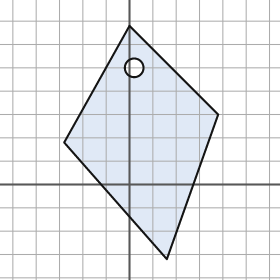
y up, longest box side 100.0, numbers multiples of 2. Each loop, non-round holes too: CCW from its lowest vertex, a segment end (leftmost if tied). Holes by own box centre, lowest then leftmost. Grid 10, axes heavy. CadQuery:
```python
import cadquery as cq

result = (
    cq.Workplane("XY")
    .moveTo(16.0, -32.0)
    .lineTo(38.0, 30.0)
    .lineTo(0.0, 68.0)
    .lineTo(-28.0, 18.0)
    .close()
    .moveTo(2.0, 50.0)
    .circle(4.0)
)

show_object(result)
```